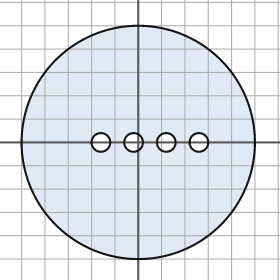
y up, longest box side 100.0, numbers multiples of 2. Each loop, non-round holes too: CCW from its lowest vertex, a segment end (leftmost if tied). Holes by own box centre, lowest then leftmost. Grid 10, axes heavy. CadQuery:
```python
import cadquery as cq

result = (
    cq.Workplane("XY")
    .moveTo(0.0, 0.0)
    .circle(50.0)
    .moveTo(-16.0, 0.0)
    .circle(4.0)
    .moveTo(-2.0, 0.0)
    .circle(4.0)
    .moveTo(12.0, 0.0)
    .circle(4.0)
    .moveTo(26.0, 0.0)
    .circle(4.0)
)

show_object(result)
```